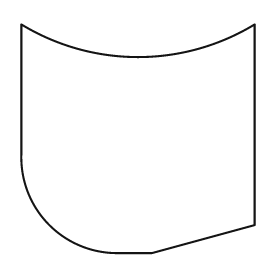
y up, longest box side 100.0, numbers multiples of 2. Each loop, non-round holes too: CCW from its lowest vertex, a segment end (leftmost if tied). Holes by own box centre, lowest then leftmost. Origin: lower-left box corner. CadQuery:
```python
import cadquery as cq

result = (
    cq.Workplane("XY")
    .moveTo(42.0, 0.0)
    .lineTo(56.0, 0.0)
    .lineTo(100.0, 12.0)
    .lineTo(100.0, 98.0)
    .threePointArc((50.0, 84.0), (0.0, 98.0))
    .lineTo(0.0, 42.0)
    .threePointArc((12.0, 12.0), (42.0, 0.0))
    .close()
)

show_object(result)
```